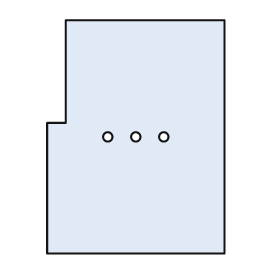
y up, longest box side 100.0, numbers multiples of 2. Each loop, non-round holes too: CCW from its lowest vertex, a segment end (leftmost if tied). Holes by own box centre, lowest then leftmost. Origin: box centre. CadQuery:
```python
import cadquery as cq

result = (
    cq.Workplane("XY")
    .moveTo(-38.0, -50.0)
    .lineTo(38.0, -50.0)
    .lineTo(38.0, 50.0)
    .lineTo(-30.0, 50.0)
    .lineTo(-30.0, 6.0)
    .lineTo(-38.0, 6.0)
    .close()
    .moveTo(-12.0, 0.0)
    .circle(2.0)
    .moveTo(0.0, 0.0)
    .circle(2.0)
    .moveTo(12.0, 0.0)
    .circle(2.0)
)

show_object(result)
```